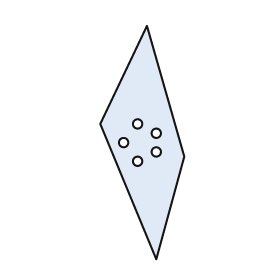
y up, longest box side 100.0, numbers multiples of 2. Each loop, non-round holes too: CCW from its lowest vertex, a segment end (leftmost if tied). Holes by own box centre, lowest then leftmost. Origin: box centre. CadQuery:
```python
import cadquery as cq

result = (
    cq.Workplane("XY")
    .moveTo(6.0, -50.0)
    .lineTo(18.0, -6.0)
    .lineTo(2.0, 50.0)
    .lineTo(-18.0, 8.0)
    .close()
    .moveTo(-2.0, -8.0)
    .circle(2.0)
    .moveTo(6.0, -4.0)
    .circle(2.0)
    .moveTo(-8.0, 0.0)
    .circle(2.0)
    .moveTo(6.0, 4.0)
    .circle(2.0)
    .moveTo(-2.0, 8.0)
    .circle(2.0)
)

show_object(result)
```